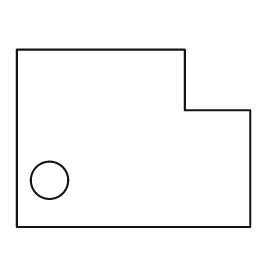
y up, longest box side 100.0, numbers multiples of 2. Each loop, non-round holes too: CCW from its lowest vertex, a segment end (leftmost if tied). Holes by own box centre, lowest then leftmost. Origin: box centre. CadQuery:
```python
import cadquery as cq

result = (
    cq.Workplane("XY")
    .moveTo(-50.0, -38.0)
    .lineTo(50.0, -38.0)
    .lineTo(50.0, 12.0)
    .lineTo(22.0, 12.0)
    .lineTo(22.0, 38.0)
    .lineTo(-50.0, 38.0)
    .close()
    .moveTo(-36.0, -18.0)
    .circle(8.0)
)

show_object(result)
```